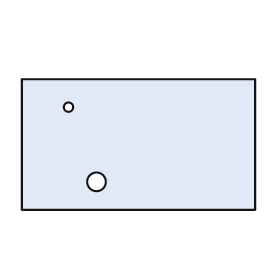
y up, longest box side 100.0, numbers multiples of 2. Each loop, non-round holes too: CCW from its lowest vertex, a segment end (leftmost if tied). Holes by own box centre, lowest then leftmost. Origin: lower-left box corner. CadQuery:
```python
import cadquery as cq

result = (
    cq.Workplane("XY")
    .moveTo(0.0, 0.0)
    .lineTo(100.0, 0.0)
    .lineTo(100.0, 56.0)
    .lineTo(0.0, 56.0)
    .close()
    .moveTo(32.0, 12.0)
    .circle(4.0)
    .moveTo(20.0, 44.0)
    .circle(2.0)
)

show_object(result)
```